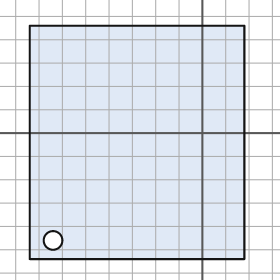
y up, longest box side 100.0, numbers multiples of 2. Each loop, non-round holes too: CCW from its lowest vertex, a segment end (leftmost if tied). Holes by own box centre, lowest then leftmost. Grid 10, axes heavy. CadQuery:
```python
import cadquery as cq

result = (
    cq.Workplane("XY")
    .moveTo(-74.0, -54.0)
    .lineTo(18.0, -54.0)
    .lineTo(18.0, 46.0)
    .lineTo(-74.0, 46.0)
    .close()
    .moveTo(-64.0, -46.0)
    .circle(4.0)
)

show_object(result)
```